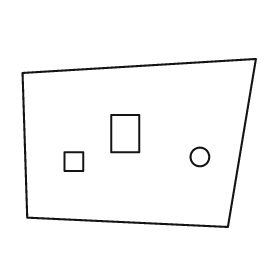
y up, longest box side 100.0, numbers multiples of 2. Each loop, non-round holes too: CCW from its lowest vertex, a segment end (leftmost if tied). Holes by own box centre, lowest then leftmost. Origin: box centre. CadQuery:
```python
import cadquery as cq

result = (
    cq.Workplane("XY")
    .moveTo(38.0, -36.0)
    .lineTo(50.0, 36.0)
    .lineTo(-50.0, 30.0)
    .lineTo(-48.0, -32.0)
    .close()
    .moveTo(-32.0, -12.0)
    .lineTo(-24.0, -12.0)
    .lineTo(-24.0, -4.0)
    .lineTo(-32.0, -4.0)
    .close()
    .moveTo(26.0, -6.0)
    .circle(4.0)
    .moveTo(-12.0, -4.0)
    .lineTo(0.0, -4.0)
    .lineTo(0.0, 12.0)
    .lineTo(-12.0, 12.0)
    .close()
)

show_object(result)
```